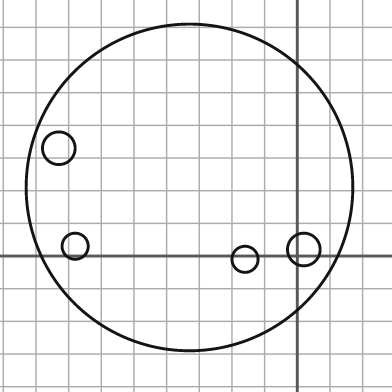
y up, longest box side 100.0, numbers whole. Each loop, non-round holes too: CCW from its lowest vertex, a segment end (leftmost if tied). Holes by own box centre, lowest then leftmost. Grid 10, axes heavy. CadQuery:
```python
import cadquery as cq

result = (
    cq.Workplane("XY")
    .moveTo(-33.0, 21.0)
    .circle(50.0)
    .moveTo(-16.0, -1.0)
    .circle(4.0)
    .moveTo(2.0, 2.0)
    .circle(5.0)
    .moveTo(-68.0, 3.0)
    .circle(4.0)
    .moveTo(-73.0, 33.0)
    .circle(5.0)
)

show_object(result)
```